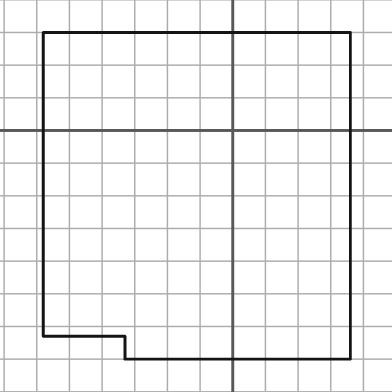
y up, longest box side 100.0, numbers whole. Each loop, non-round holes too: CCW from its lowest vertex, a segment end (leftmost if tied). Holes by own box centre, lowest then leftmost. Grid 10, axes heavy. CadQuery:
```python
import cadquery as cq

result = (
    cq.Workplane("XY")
    .moveTo(-33.0, -70.0)
    .lineTo(36.0, -70.0)
    .lineTo(36.0, 30.0)
    .lineTo(-58.0, 30.0)
    .lineTo(-58.0, -63.0)
    .lineTo(-33.0, -63.0)
    .close()
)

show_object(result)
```